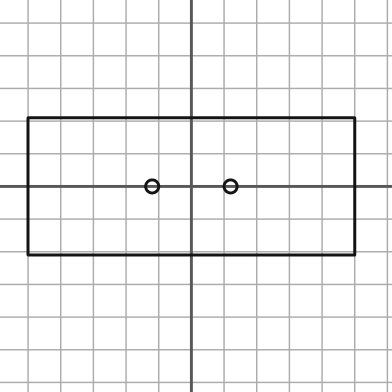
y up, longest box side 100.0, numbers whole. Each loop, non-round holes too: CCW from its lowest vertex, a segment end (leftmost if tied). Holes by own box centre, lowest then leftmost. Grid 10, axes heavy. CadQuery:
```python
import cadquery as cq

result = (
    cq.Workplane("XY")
    .moveTo(-50.0, -21.0)
    .lineTo(50.0, -21.0)
    .lineTo(50.0, 21.0)
    .lineTo(-50.0, 21.0)
    .close()
    .moveTo(-12.0, 0.0)
    .circle(2.0)
    .moveTo(12.0, 0.0)
    .circle(2.0)
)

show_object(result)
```